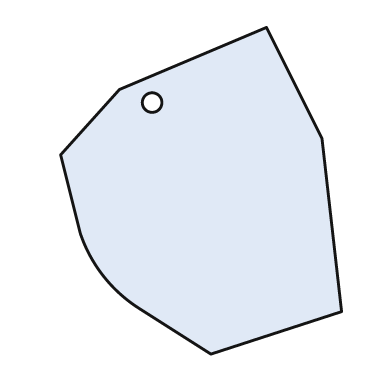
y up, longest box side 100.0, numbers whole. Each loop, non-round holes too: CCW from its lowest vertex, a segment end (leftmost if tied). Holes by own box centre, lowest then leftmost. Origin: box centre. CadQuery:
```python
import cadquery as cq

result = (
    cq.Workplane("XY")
    .moveTo(3.0, -50.0)
    .lineTo(43.0, -37.0)
    .lineTo(37.0, 16.0)
    .lineTo(20.0, 50.0)
    .lineTo(-25.0, 31.0)
    .lineTo(-43.0, 11.0)
    .lineTo(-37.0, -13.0)
    .threePointArc((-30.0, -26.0), (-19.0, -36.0))
    .close()
    .moveTo(-15.0, 27.0)
    .circle(3.0)
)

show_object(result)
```